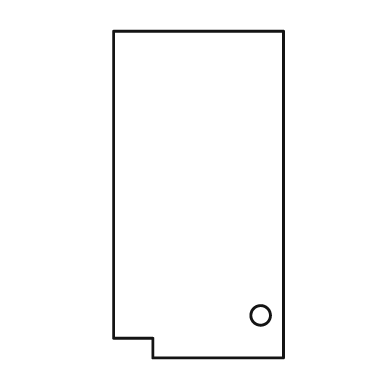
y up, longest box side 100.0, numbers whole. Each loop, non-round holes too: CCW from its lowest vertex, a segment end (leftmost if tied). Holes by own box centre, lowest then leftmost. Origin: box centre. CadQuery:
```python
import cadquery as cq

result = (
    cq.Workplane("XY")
    .moveTo(-14.0, -50.0)
    .lineTo(26.0, -50.0)
    .lineTo(26.0, 50.0)
    .lineTo(-26.0, 50.0)
    .lineTo(-26.0, -44.0)
    .lineTo(-14.0, -44.0)
    .close()
    .moveTo(19.0, -37.0)
    .circle(3.0)
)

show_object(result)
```